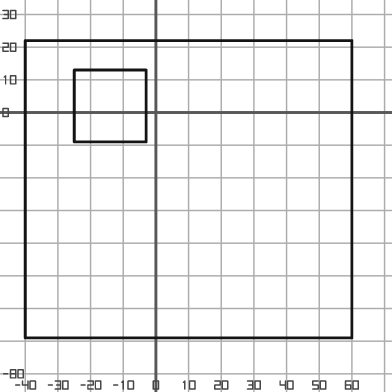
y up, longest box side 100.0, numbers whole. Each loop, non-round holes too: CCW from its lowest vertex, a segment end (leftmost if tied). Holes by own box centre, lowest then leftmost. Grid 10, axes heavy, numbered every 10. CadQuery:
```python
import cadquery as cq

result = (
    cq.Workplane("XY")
    .moveTo(-40.0, -69.0)
    .lineTo(60.0, -69.0)
    .lineTo(60.0, 22.0)
    .lineTo(-40.0, 22.0)
    .close()
    .moveTo(-25.0, -9.0)
    .lineTo(-3.0, -9.0)
    .lineTo(-3.0, 13.0)
    .lineTo(-25.0, 13.0)
    .close()
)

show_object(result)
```